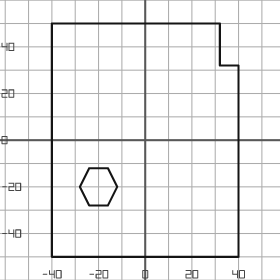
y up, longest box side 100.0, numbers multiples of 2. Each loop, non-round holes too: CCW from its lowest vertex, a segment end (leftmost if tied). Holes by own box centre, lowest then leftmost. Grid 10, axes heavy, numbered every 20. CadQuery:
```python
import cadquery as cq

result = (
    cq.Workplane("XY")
    .moveTo(-40.0, -50.0)
    .lineTo(40.0, -50.0)
    .lineTo(40.0, 32.0)
    .lineTo(32.0, 32.0)
    .lineTo(32.0, 50.0)
    .lineTo(-40.0, 50.0)
    .close()
    .moveTo(-24.0, -28.0)
    .lineTo(-16.0, -28.0)
    .lineTo(-12.0, -20.0)
    .lineTo(-16.0, -12.0)
    .lineTo(-24.0, -12.0)
    .lineTo(-28.0, -20.0)
    .close()
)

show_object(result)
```